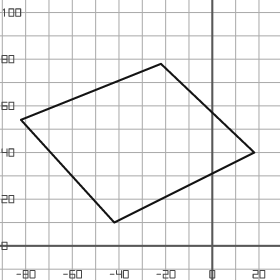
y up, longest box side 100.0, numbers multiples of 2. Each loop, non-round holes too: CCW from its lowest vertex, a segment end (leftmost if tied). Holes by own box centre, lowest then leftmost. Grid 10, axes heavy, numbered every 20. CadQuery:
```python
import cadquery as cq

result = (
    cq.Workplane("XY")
    .moveTo(-42.0, 10.0)
    .lineTo(18.0, 40.0)
    .lineTo(-22.0, 78.0)
    .lineTo(-82.0, 54.0)
    .close()
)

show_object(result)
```